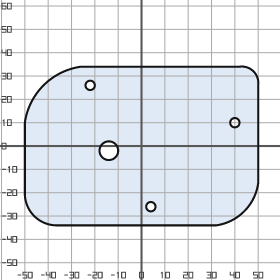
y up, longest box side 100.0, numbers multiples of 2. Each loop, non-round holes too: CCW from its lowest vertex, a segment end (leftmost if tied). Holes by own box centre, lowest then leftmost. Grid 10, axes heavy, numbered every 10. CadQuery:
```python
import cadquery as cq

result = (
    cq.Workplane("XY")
    .moveTo(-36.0, -34.0)
    .lineTo(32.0, -34.0)
    .threePointArc((44.0, -28.0), (50.0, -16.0))
    .lineTo(50.0, 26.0)
    .threePointArc((48.0, 32.0), (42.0, 34.0))
    .lineTo(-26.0, 34.0)
    .threePointArc((-42.0, 26.0), (-50.0, 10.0))
    .lineTo(-50.0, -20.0)
    .threePointArc((-46.0, -30.0), (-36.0, -34.0))
    .close()
    .moveTo(4.0, -26.0)
    .circle(2.0)
    .moveTo(-14.0, -2.0)
    .circle(4.0)
    .moveTo(40.0, 10.0)
    .circle(2.0)
    .moveTo(-22.0, 26.0)
    .circle(2.0)
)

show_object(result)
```